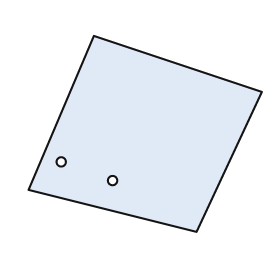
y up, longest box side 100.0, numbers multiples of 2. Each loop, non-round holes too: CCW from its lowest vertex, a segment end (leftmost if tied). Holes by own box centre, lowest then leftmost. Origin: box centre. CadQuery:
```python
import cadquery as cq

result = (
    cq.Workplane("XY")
    .moveTo(22.0, -42.0)
    .lineTo(50.0, 18.0)
    .lineTo(-22.0, 42.0)
    .lineTo(-50.0, -24.0)
    .close()
    .moveTo(-14.0, -20.0)
    .circle(2.0)
    .moveTo(-36.0, -12.0)
    .circle(2.0)
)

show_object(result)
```